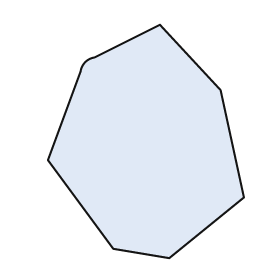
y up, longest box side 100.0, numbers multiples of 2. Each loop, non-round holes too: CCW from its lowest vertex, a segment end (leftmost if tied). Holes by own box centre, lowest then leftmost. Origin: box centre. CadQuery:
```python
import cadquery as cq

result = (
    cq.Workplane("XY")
    .moveTo(10.0, -50.0)
    .lineTo(42.0, -24.0)
    .lineTo(32.0, 22.0)
    .lineTo(6.0, 50.0)
    .lineTo(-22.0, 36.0)
    .threePointArc((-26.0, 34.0), (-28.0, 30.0))
    .lineTo(-42.0, -8.0)
    .lineTo(-14.0, -46.0)
    .close()
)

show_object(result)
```